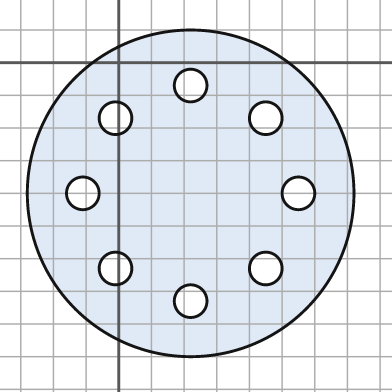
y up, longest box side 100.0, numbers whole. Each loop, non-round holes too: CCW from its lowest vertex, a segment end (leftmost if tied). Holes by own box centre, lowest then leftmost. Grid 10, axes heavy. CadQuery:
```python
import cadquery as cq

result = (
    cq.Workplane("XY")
    .moveTo(22.0, -40.0)
    .circle(50.0)
    .moveTo(22.0, -73.0)
    .circle(5.0)
    .moveTo(-1.0, -63.0)
    .circle(5.0)
    .moveTo(45.0, -63.0)
    .circle(5.0)
    .moveTo(-11.0, -40.0)
    .circle(5.0)
    .moveTo(55.0, -40.0)
    .circle(5.0)
    .moveTo(-1.0, -17.0)
    .circle(5.0)
    .moveTo(45.0, -17.0)
    .circle(5.0)
    .moveTo(22.0, -7.0)
    .circle(5.0)
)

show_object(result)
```